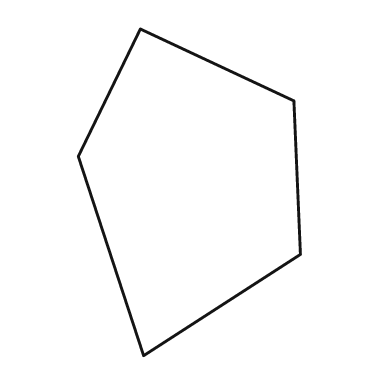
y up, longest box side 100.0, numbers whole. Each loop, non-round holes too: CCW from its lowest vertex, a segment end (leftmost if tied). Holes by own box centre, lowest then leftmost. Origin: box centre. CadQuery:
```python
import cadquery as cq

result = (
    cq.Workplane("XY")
    .moveTo(-14.0, -50.0)
    .lineTo(34.0, -19.0)
    .lineTo(32.0, 28.0)
    .lineTo(-15.0, 50.0)
    .lineTo(-34.0, 11.0)
    .close()
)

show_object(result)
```